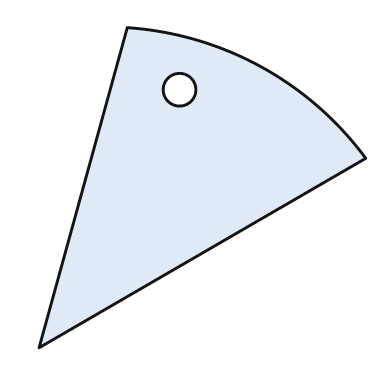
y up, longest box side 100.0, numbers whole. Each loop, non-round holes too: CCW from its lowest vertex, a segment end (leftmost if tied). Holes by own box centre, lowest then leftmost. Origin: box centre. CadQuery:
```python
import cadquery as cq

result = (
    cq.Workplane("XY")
    .moveTo(-50.0, -49.0)
    .lineTo(50.0, 9.0)
    .threePointArc((18.0, 37.0), (-23.0, 49.0))
    .close()
    .moveTo(-7.0, 30.0)
    .circle(5.0)
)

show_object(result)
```